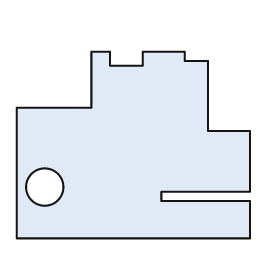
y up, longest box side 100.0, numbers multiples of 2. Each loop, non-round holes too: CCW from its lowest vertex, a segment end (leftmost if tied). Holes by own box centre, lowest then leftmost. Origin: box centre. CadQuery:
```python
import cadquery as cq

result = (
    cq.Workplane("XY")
    .moveTo(-50.0, -40.0)
    .lineTo(50.0, -40.0)
    .lineTo(50.0, -24.0)
    .lineTo(12.0, -24.0)
    .lineTo(12.0, -20.0)
    .lineTo(50.0, -20.0)
    .lineTo(50.0, 6.0)
    .lineTo(32.0, 6.0)
    .lineTo(32.0, 36.0)
    .lineTo(22.0, 36.0)
    .lineTo(22.0, 40.0)
    .lineTo(4.0, 40.0)
    .lineTo(4.0, 34.0)
    .lineTo(-10.0, 34.0)
    .lineTo(-10.0, 40.0)
    .lineTo(-18.0, 40.0)
    .lineTo(-18.0, 16.0)
    .lineTo(-50.0, 16.0)
    .close()
    .moveTo(-38.0, -18.0)
    .circle(8.0)
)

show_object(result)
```